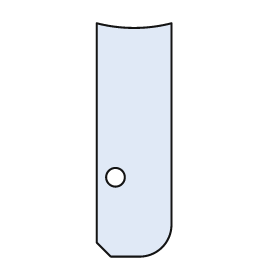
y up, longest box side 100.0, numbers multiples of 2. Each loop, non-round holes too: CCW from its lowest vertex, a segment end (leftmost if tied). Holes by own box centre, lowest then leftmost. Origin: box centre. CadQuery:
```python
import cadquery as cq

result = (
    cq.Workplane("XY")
    .moveTo(-10.0, -50.0)
    .lineTo(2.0, -50.0)
    .threePointArc((12.0, -46.0), (16.0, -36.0))
    .lineTo(16.0, 50.0)
    .threePointArc((0.0, 48.0), (-16.0, 50.0))
    .lineTo(-16.0, -44.0)
    .close()
    .moveTo(-8.0, -16.0)
    .circle(4.0)
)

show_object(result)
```